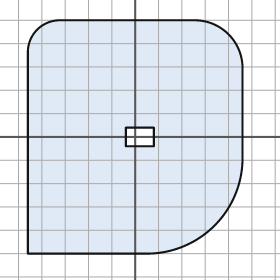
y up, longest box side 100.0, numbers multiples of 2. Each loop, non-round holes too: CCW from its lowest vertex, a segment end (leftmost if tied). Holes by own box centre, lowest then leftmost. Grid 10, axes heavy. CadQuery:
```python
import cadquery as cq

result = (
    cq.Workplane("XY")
    .moveTo(-46.0, -50.0)
    .lineTo(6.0, -50.0)
    .threePointArc((34.0, -38.0), (46.0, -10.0))
    .lineTo(46.0, 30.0)
    .threePointArc((40.0, 44.0), (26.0, 50.0))
    .lineTo(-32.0, 50.0)
    .threePointArc((-42.0, 46.0), (-46.0, 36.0))
    .close()
    .moveTo(-4.0, -4.0)
    .lineTo(8.0, -4.0)
    .lineTo(8.0, 4.0)
    .lineTo(-4.0, 4.0)
    .close()
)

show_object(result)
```